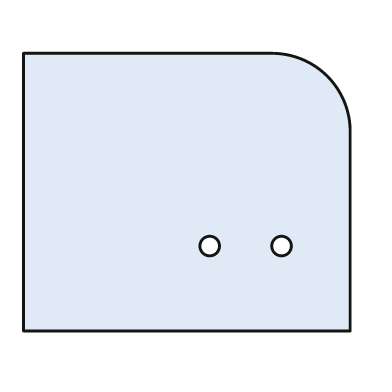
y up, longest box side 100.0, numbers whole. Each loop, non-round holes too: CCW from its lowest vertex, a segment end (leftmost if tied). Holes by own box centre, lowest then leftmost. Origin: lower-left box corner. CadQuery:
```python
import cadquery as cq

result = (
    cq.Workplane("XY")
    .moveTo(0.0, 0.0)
    .lineTo(100.0, 0.0)
    .lineTo(100.0, 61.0)
    .threePointArc((93.0, 78.0), (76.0, 85.0))
    .lineTo(0.0, 85.0)
    .close()
    .moveTo(57.0, 26.0)
    .circle(3.0)
    .moveTo(79.0, 26.0)
    .circle(3.0)
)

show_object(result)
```